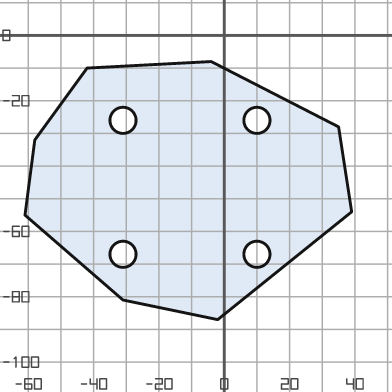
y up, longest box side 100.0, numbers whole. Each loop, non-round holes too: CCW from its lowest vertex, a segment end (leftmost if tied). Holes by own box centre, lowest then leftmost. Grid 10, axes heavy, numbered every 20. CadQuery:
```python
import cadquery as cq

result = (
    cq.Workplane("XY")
    .moveTo(-2.0, -87.0)
    .lineTo(39.0, -54.0)
    .lineTo(35.0, -28.0)
    .lineTo(-4.0, -8.0)
    .lineTo(-42.0, -10.0)
    .lineTo(-58.0, -32.0)
    .lineTo(-61.0, -55.0)
    .lineTo(-31.0, -81.0)
    .close()
    .moveTo(-31.0, -67.0)
    .circle(4.0)
    .moveTo(10.0, -67.0)
    .circle(4.0)
    .moveTo(-31.0, -26.0)
    .circle(4.0)
    .moveTo(10.0, -26.0)
    .circle(4.0)
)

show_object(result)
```